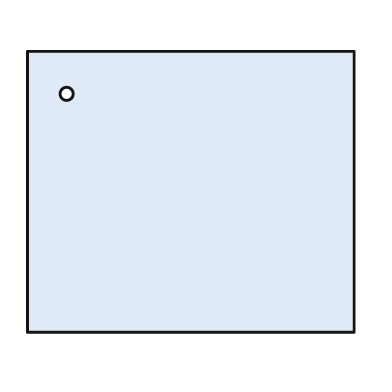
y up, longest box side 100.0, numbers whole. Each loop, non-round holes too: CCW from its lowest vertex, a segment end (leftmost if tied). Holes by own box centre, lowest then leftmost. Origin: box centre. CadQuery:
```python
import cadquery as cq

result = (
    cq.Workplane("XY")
    .moveTo(-50.0, -43.0)
    .lineTo(50.0, -43.0)
    .lineTo(50.0, 43.0)
    .lineTo(-50.0, 43.0)
    .close()
    .moveTo(-38.0, 30.0)
    .circle(2.0)
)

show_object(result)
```